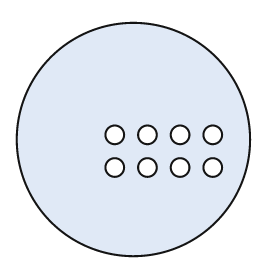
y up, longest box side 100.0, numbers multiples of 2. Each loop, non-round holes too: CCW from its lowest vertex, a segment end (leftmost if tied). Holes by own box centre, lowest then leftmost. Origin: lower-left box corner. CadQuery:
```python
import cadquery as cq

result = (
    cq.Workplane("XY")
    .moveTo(50.0, 50.0)
    .circle(50.0)
    .moveTo(42.0, 38.0)
    .circle(4.0)
    .moveTo(56.0, 38.0)
    .circle(4.0)
    .moveTo(70.0, 38.0)
    .circle(4.0)
    .moveTo(84.0, 38.0)
    .circle(4.0)
    .moveTo(42.0, 52.0)
    .circle(4.0)
    .moveTo(56.0, 52.0)
    .circle(4.0)
    .moveTo(70.0, 52.0)
    .circle(4.0)
    .moveTo(84.0, 52.0)
    .circle(4.0)
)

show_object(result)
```